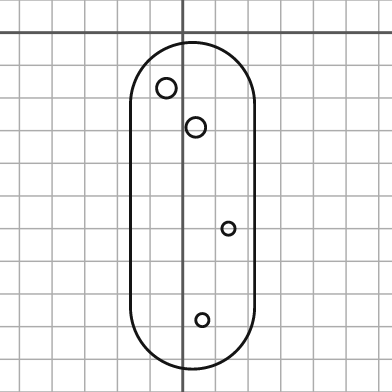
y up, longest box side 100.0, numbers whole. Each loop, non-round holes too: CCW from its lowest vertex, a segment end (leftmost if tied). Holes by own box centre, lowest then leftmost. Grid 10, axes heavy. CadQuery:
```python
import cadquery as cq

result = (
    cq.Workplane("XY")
    .moveTo(-16.0, -84.0)
    .threePointArc((3.0, -103.0), (22.0, -84.0))
    .lineTo(22.0, -22.0)
    .threePointArc((3.0, -3.0), (-16.0, -22.0))
    .close()
    .moveTo(6.0, -88.0)
    .circle(2.0)
    .moveTo(14.0, -60.0)
    .circle(2.0)
    .moveTo(4.0, -29.0)
    .circle(3.0)
    .moveTo(-5.0, -17.0)
    .circle(3.0)
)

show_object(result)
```